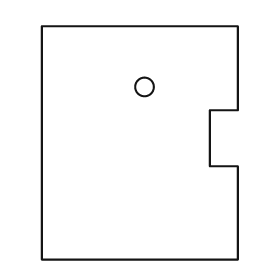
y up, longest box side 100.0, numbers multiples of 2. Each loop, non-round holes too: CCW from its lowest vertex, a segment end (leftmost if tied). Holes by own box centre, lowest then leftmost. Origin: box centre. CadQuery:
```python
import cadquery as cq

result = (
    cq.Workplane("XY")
    .moveTo(-42.0, -50.0)
    .lineTo(42.0, -50.0)
    .lineTo(42.0, -10.0)
    .lineTo(30.0, -10.0)
    .lineTo(30.0, 14.0)
    .lineTo(42.0, 14.0)
    .lineTo(42.0, 50.0)
    .lineTo(-42.0, 50.0)
    .close()
    .moveTo(2.0, 24.0)
    .circle(4.0)
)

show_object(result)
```